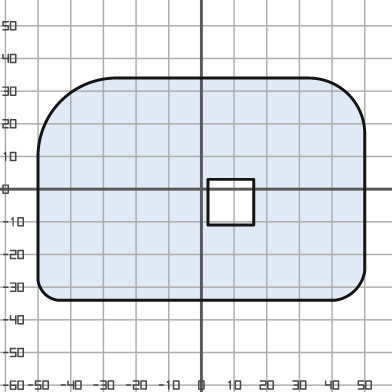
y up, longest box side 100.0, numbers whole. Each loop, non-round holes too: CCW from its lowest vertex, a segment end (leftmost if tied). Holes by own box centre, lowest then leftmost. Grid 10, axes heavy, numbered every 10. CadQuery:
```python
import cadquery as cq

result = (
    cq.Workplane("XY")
    .moveTo(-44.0, -34.0)
    .lineTo(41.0, -34.0)
    .threePointArc((47.0, -31.0), (50.0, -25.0))
    .lineTo(50.0, 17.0)
    .threePointArc((45.0, 29.0), (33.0, 34.0))
    .lineTo(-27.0, 34.0)
    .threePointArc((-43.0, 27.0), (-50.0, 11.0))
    .lineTo(-50.0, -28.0)
    .threePointArc((-48.0, -32.0), (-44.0, -34.0))
    .close()
    .moveTo(2.0, -11.0)
    .lineTo(16.0, -11.0)
    .lineTo(16.0, 3.0)
    .lineTo(2.0, 3.0)
    .close()
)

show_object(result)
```